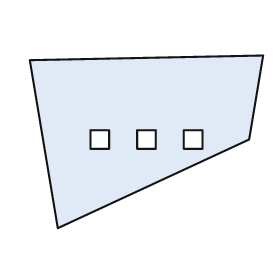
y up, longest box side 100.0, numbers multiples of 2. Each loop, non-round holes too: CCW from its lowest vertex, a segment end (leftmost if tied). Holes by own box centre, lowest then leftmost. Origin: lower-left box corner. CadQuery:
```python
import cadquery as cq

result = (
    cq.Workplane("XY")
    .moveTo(12.0, 0.0)
    .lineTo(94.0, 38.0)
    .lineTo(100.0, 74.0)
    .lineTo(0.0, 72.0)
    .close()
    .moveTo(26.0, 34.0)
    .lineTo(34.0, 34.0)
    .lineTo(34.0, 42.0)
    .lineTo(26.0, 42.0)
    .close()
    .moveTo(46.0, 34.0)
    .lineTo(54.0, 34.0)
    .lineTo(54.0, 42.0)
    .lineTo(46.0, 42.0)
    .close()
    .moveTo(66.0, 34.0)
    .lineTo(74.0, 34.0)
    .lineTo(74.0, 42.0)
    .lineTo(66.0, 42.0)
    .close()
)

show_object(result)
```